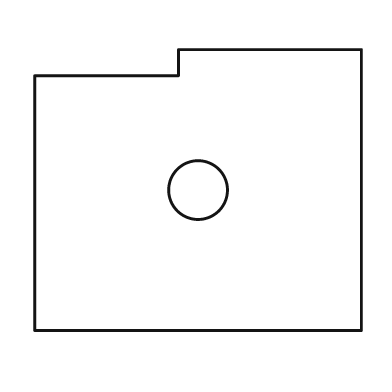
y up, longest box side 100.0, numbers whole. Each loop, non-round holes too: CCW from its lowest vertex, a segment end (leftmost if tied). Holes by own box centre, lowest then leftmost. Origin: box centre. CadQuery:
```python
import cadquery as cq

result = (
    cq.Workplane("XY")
    .moveTo(-50.0, -43.0)
    .lineTo(50.0, -43.0)
    .lineTo(50.0, 43.0)
    .lineTo(-6.0, 43.0)
    .lineTo(-6.0, 35.0)
    .lineTo(-50.0, 35.0)
    .close()
    .moveTo(0.0, 0.0)
    .circle(9.0)
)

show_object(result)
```